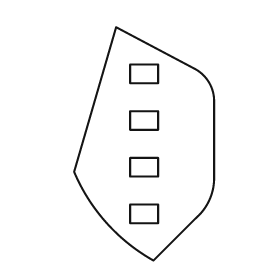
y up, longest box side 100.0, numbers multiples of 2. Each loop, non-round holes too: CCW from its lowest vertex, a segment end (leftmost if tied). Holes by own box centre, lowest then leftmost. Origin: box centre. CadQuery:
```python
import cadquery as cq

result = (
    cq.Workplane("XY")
    .moveTo(4.0, -50.0)
    .lineTo(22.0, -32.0)
    .threePointArc((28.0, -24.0), (30.0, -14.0))
    .lineTo(30.0, 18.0)
    .threePointArc((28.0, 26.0), (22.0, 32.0))
    .lineTo(-12.0, 50.0)
    .lineTo(-30.0, -12.0)
    .threePointArc((-16.0, -34.0), (4.0, -50.0))
    .close()
    .moveTo(-6.0, -34.0)
    .lineTo(6.0, -34.0)
    .lineTo(6.0, -26.0)
    .lineTo(-6.0, -26.0)
    .close()
    .moveTo(-6.0, -14.0)
    .lineTo(6.0, -14.0)
    .lineTo(6.0, -6.0)
    .lineTo(-6.0, -6.0)
    .close()
    .moveTo(-6.0, 6.0)
    .lineTo(6.0, 6.0)
    .lineTo(6.0, 14.0)
    .lineTo(-6.0, 14.0)
    .close()
    .moveTo(-6.0, 26.0)
    .lineTo(6.0, 26.0)
    .lineTo(6.0, 34.0)
    .lineTo(-6.0, 34.0)
    .close()
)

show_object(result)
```